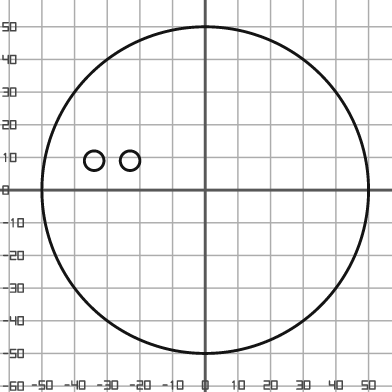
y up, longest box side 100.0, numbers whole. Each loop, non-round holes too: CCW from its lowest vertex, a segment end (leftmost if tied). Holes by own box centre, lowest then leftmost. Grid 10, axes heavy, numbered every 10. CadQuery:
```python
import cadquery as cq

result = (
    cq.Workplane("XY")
    .moveTo(0.0, 0.0)
    .circle(50.0)
    .moveTo(-34.0, 9.0)
    .circle(3.0)
    .moveTo(-23.0, 9.0)
    .circle(3.0)
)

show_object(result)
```